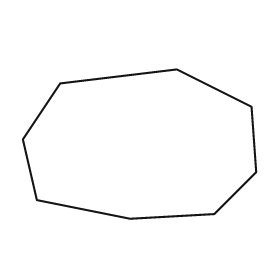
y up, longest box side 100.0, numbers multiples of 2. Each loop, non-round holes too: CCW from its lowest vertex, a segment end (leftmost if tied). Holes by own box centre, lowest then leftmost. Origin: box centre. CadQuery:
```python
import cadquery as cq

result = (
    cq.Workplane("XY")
    .moveTo(-4.0, -32.0)
    .lineTo(32.0, -30.0)
    .lineTo(50.0, -12.0)
    .lineTo(48.0, 16.0)
    .lineTo(16.0, 32.0)
    .lineTo(-34.0, 26.0)
    .lineTo(-50.0, 2.0)
    .lineTo(-44.0, -24.0)
    .close()
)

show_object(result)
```